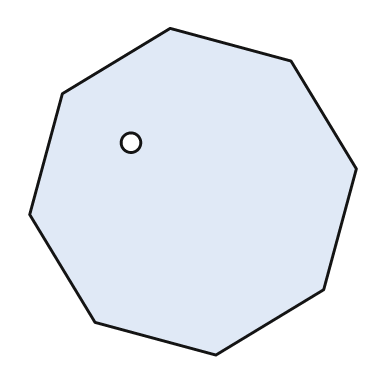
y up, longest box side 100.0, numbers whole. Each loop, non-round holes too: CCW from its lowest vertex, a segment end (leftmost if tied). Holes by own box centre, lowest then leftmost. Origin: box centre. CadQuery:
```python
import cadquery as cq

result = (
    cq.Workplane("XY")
    .moveTo(7.0, -50.0)
    .lineTo(40.0, -30.0)
    .lineTo(50.0, 7.0)
    .lineTo(30.0, 40.0)
    .lineTo(-7.0, 50.0)
    .lineTo(-40.0, 30.0)
    .lineTo(-50.0, -7.0)
    .lineTo(-30.0, -40.0)
    .close()
    .moveTo(-19.0, 15.0)
    .circle(3.0)
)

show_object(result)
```